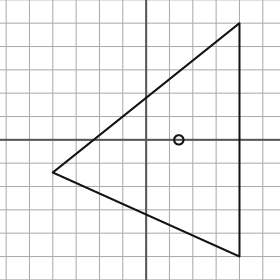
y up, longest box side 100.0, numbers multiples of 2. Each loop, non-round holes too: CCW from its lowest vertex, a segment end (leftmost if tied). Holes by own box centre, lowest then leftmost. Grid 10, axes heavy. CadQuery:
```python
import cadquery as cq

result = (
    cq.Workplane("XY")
    .moveTo(40.0, -50.0)
    .lineTo(40.0, 50.0)
    .lineTo(-40.0, -14.0)
    .close()
    .moveTo(14.0, 0.0)
    .circle(2.0)
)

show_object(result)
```